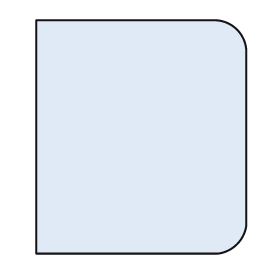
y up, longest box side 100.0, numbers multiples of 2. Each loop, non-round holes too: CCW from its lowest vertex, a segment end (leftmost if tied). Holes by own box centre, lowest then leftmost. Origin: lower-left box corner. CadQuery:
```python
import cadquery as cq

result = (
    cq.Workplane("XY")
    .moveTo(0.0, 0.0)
    .lineTo(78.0, 0.0)
    .threePointArc((86.0, 4.0), (90.0, 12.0))
    .lineTo(90.0, 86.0)
    .threePointArc((86.0, 96.0), (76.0, 100.0))
    .lineTo(0.0, 100.0)
    .close()
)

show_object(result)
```